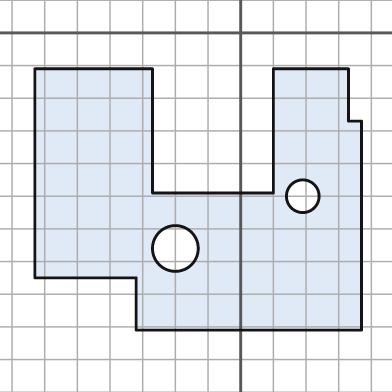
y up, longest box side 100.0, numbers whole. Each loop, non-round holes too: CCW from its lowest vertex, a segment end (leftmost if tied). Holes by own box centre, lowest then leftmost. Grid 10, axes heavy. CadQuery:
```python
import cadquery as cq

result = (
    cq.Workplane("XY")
    .moveTo(-32.0, -91.0)
    .lineTo(37.0, -91.0)
    .lineTo(37.0, -27.0)
    .lineTo(33.0, -27.0)
    .lineTo(33.0, -11.0)
    .lineTo(10.0, -11.0)
    .lineTo(10.0, -49.0)
    .lineTo(-27.0, -49.0)
    .lineTo(-27.0, -11.0)
    .lineTo(-63.0, -11.0)
    .lineTo(-63.0, -75.0)
    .lineTo(-32.0, -75.0)
    .close()
    .moveTo(-20.0, -66.0)
    .circle(7.0)
    .moveTo(19.0, -50.0)
    .circle(5.0)
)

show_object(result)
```